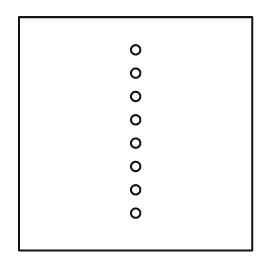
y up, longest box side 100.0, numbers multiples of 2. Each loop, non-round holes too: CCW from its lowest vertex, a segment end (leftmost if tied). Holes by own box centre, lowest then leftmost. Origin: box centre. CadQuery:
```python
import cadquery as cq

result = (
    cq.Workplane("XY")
    .moveTo(-50.0, -50.0)
    .lineTo(50.0, -50.0)
    .lineTo(50.0, 50.0)
    .lineTo(-50.0, 50.0)
    .close()
    .moveTo(0.0, -34.0)
    .circle(2.0)
    .moveTo(0.0, -24.0)
    .circle(2.0)
    .moveTo(0.0, -14.0)
    .circle(2.0)
    .moveTo(0.0, -4.0)
    .circle(2.0)
    .moveTo(0.0, 6.0)
    .circle(2.0)
    .moveTo(0.0, 16.0)
    .circle(2.0)
    .moveTo(0.0, 26.0)
    .circle(2.0)
    .moveTo(0.0, 36.0)
    .circle(2.0)
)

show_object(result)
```